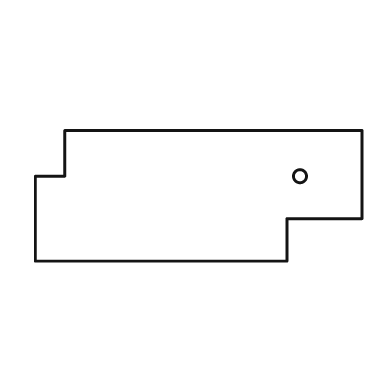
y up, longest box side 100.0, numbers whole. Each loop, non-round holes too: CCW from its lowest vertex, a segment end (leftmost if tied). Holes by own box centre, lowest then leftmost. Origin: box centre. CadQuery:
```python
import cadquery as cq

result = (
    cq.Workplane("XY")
    .moveTo(-50.0, -20.0)
    .lineTo(27.0, -20.0)
    .lineTo(27.0, -7.0)
    .lineTo(50.0, -7.0)
    .lineTo(50.0, 20.0)
    .lineTo(-41.0, 20.0)
    .lineTo(-41.0, 6.0)
    .lineTo(-50.0, 6.0)
    .close()
    .moveTo(31.0, 6.0)
    .circle(2.0)
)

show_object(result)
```